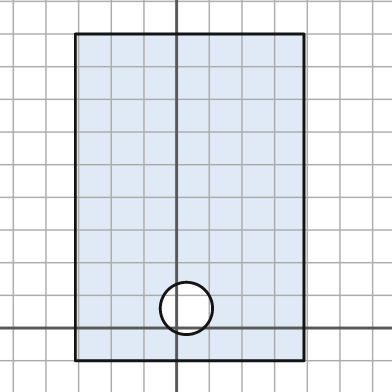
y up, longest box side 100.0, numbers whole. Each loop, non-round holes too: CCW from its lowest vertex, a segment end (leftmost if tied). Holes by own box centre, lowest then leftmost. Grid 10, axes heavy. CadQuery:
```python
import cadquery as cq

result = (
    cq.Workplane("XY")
    .moveTo(-31.0, -10.0)
    .lineTo(39.0, -10.0)
    .lineTo(39.0, 90.0)
    .lineTo(-31.0, 90.0)
    .close()
    .moveTo(3.0, 6.0)
    .circle(8.0)
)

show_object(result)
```